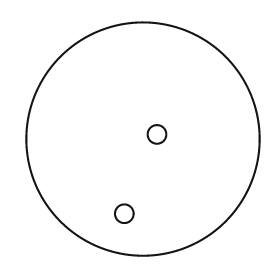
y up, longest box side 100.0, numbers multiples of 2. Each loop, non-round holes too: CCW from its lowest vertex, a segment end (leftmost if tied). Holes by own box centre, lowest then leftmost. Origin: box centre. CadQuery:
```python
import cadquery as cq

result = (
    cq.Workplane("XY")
    .moveTo(0.0, 0.0)
    .circle(50.0)
    .moveTo(-8.0, -32.0)
    .circle(4.0)
    .moveTo(6.0, 2.0)
    .circle(4.0)
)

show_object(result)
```